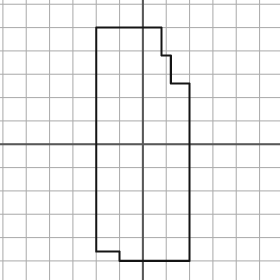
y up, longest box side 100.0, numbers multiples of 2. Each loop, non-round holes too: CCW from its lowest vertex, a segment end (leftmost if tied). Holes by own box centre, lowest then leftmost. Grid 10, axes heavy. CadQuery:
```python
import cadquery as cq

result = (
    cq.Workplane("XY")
    .moveTo(-10.0, -50.0)
    .lineTo(20.0, -50.0)
    .lineTo(20.0, 26.0)
    .lineTo(12.0, 26.0)
    .lineTo(12.0, 38.0)
    .lineTo(8.0, 38.0)
    .lineTo(8.0, 50.0)
    .lineTo(-20.0, 50.0)
    .lineTo(-20.0, -46.0)
    .lineTo(-10.0, -46.0)
    .close()
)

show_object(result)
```